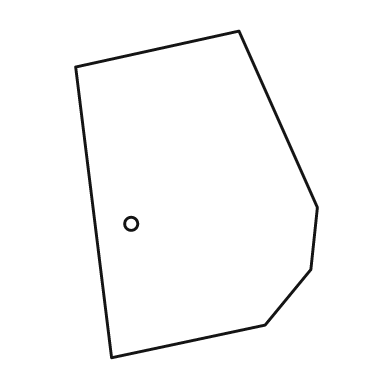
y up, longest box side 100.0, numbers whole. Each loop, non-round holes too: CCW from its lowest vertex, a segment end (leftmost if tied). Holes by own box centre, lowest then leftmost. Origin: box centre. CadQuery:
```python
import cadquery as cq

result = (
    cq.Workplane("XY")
    .moveTo(-26.0, -50.0)
    .lineTo(21.0, -40.0)
    .lineTo(35.0, -23.0)
    .lineTo(37.0, -4.0)
    .lineTo(13.0, 50.0)
    .lineTo(-37.0, 39.0)
    .close()
    .moveTo(-20.0, -9.0)
    .circle(2.0)
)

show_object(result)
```